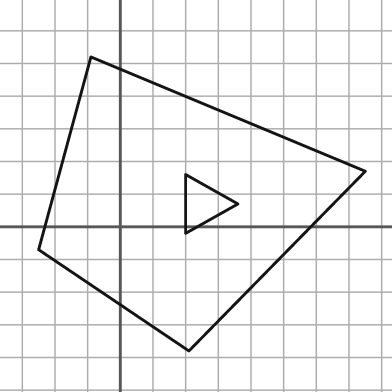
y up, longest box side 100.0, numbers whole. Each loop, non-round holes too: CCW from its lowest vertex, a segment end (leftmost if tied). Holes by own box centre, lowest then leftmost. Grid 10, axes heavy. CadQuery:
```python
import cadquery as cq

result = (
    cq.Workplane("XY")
    .moveTo(21.0, -38.0)
    .lineTo(75.0, 17.0)
    .lineTo(-9.0, 52.0)
    .lineTo(-25.0, -7.0)
    .close()
    .moveTo(20.0, -2.0)
    .lineTo(36.0, 7.0)
    .lineTo(20.0, 16.0)
    .close()
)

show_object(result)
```